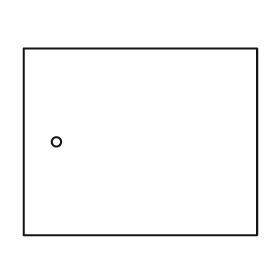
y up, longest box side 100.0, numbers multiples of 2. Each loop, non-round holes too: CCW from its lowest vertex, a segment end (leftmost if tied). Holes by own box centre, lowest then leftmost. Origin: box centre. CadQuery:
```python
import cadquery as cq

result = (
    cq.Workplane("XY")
    .moveTo(-50.0, -40.0)
    .lineTo(50.0, -40.0)
    .lineTo(50.0, 40.0)
    .lineTo(-50.0, 40.0)
    .close()
    .moveTo(-36.0, 0.0)
    .circle(2.0)
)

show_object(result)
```